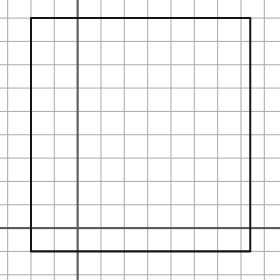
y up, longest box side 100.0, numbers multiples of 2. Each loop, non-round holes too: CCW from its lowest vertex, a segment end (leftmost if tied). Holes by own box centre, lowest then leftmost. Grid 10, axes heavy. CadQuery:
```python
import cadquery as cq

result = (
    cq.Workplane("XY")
    .moveTo(-20.0, -10.0)
    .lineTo(74.0, -10.0)
    .lineTo(74.0, 90.0)
    .lineTo(-20.0, 90.0)
    .close()
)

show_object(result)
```